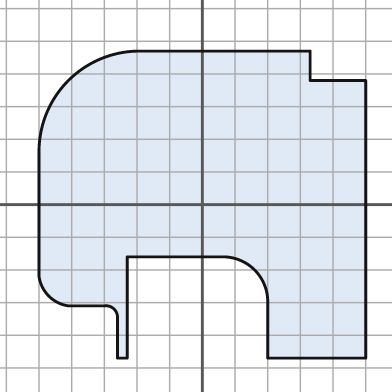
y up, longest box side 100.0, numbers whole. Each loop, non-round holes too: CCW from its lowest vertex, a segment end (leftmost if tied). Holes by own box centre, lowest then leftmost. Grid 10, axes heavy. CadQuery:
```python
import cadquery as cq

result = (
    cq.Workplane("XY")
    .moveTo(-26.0, -47.0)
    .lineTo(-23.0, -47.0)
    .lineTo(-23.0, -16.0)
    .lineTo(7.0, -16.0)
    .threePointArc((16.0, -20.0), (20.0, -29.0))
    .lineTo(20.0, -47.0)
    .lineTo(50.0, -47.0)
    .lineTo(50.0, 38.0)
    .lineTo(33.0, 38.0)
    .lineTo(33.0, 47.0)
    .lineTo(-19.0, 47.0)
    .threePointArc((-41.0, 38.0), (-50.0, 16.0))
    .lineTo(-50.0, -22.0)
    .threePointArc((-47.0, -28.0), (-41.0, -31.0))
    .lineTo(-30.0, -31.0)
    .threePointArc((-27.0, -32.0), (-26.0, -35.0))
    .close()
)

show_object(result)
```